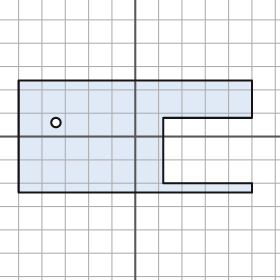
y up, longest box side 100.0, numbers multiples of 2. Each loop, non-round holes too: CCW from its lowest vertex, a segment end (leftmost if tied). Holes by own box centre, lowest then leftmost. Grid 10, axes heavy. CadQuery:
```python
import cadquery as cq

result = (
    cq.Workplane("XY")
    .moveTo(-50.0, -24.0)
    .lineTo(50.0, -24.0)
    .lineTo(50.0, -20.0)
    .lineTo(12.0, -20.0)
    .lineTo(12.0, 8.0)
    .lineTo(50.0, 8.0)
    .lineTo(50.0, 24.0)
    .lineTo(-50.0, 24.0)
    .close()
    .moveTo(-34.0, 6.0)
    .circle(2.0)
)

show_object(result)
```